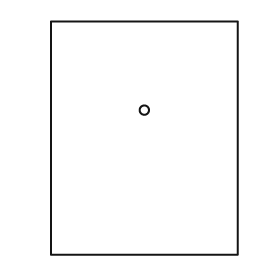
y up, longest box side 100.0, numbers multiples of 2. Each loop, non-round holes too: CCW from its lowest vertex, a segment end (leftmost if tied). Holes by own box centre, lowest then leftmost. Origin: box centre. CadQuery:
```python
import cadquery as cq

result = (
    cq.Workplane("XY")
    .moveTo(-40.0, -50.0)
    .lineTo(40.0, -50.0)
    .lineTo(40.0, 50.0)
    .lineTo(-40.0, 50.0)
    .close()
    .moveTo(0.0, 12.0)
    .circle(2.0)
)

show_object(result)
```